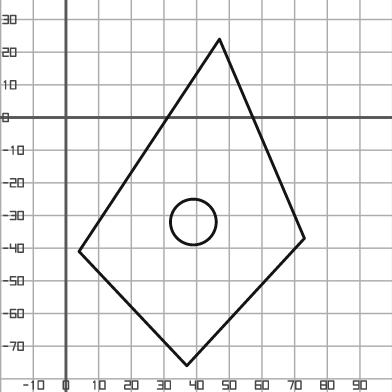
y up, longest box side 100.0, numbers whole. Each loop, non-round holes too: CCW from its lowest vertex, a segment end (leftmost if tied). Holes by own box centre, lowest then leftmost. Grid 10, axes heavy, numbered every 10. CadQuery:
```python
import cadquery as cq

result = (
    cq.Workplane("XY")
    .moveTo(37.0, -76.0)
    .lineTo(73.0, -37.0)
    .lineTo(47.0, 24.0)
    .lineTo(4.0, -41.0)
    .close()
    .moveTo(39.0, -32.0)
    .circle(7.0)
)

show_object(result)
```